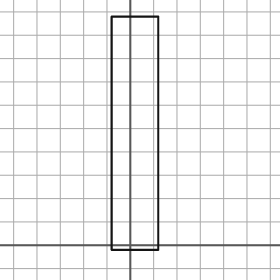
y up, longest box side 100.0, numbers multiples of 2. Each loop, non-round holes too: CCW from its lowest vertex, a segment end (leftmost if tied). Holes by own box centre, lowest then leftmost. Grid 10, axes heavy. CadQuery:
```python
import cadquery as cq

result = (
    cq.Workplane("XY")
    .moveTo(-8.0, -2.0)
    .lineTo(12.0, -2.0)
    .lineTo(12.0, 98.0)
    .lineTo(-8.0, 98.0)
    .close()
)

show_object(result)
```